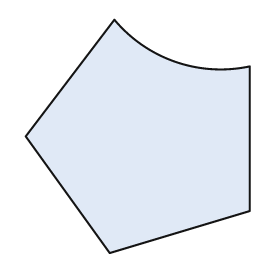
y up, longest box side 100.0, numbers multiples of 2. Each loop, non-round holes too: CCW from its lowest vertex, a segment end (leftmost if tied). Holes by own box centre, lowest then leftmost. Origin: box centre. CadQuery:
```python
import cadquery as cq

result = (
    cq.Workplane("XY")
    .moveTo(-12.0, -50.0)
    .lineTo(48.0, -32.0)
    .lineTo(48.0, 30.0)
    .threePointArc((16.0, 32.0), (-10.0, 50.0))
    .lineTo(-48.0, 0.0)
    .close()
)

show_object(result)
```